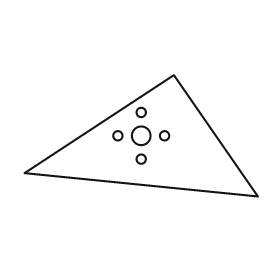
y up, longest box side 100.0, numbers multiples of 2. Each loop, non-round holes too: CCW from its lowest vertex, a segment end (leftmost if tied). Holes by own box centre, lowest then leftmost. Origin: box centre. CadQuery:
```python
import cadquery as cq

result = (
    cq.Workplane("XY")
    .moveTo(50.0, -26.0)
    .lineTo(14.0, 26.0)
    .lineTo(-50.0, -16.0)
    .close()
    .moveTo(0.0, -10.0)
    .circle(2.0)
    .moveTo(-10.0, 0.0)
    .circle(2.0)
    .moveTo(0.0, 0.0)
    .circle(4.0)
    .moveTo(10.0, 0.0)
    .circle(2.0)
    .moveTo(0.0, 10.0)
    .circle(2.0)
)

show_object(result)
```